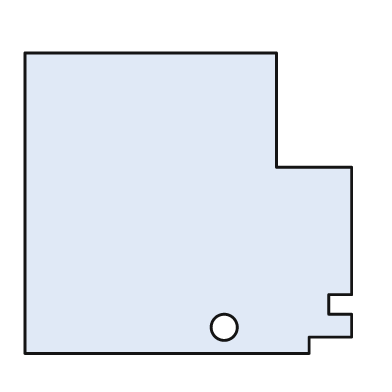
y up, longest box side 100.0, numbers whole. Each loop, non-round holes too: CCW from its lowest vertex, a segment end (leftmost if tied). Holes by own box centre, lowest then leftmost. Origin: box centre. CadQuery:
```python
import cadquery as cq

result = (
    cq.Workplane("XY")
    .moveTo(-50.0, -46.0)
    .lineTo(37.0, -46.0)
    .lineTo(37.0, -41.0)
    .lineTo(50.0, -41.0)
    .lineTo(50.0, -34.0)
    .lineTo(43.0, -34.0)
    .lineTo(43.0, -28.0)
    .lineTo(50.0, -28.0)
    .lineTo(50.0, 11.0)
    .lineTo(27.0, 11.0)
    .lineTo(27.0, 46.0)
    .lineTo(-50.0, 46.0)
    .close()
    .moveTo(11.0, -38.0)
    .circle(4.0)
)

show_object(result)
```